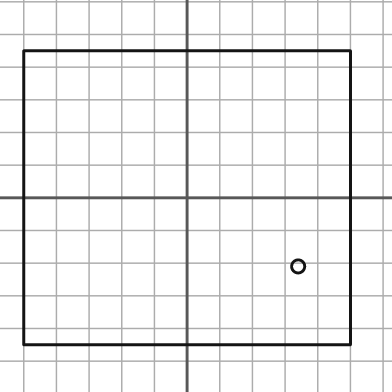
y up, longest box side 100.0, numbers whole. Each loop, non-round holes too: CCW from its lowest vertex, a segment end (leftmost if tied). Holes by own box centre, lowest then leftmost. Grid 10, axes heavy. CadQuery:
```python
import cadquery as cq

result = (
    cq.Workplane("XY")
    .moveTo(-50.0, -45.0)
    .lineTo(50.0, -45.0)
    .lineTo(50.0, 45.0)
    .lineTo(-50.0, 45.0)
    .close()
    .moveTo(34.0, -21.0)
    .circle(2.0)
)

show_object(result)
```